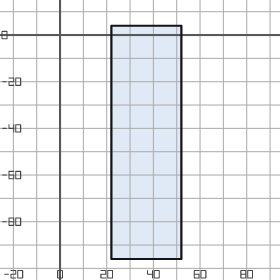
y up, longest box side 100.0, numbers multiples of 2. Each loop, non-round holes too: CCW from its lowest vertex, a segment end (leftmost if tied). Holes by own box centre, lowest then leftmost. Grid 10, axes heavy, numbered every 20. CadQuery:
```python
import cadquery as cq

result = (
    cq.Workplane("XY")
    .moveTo(22.0, -96.0)
    .lineTo(52.0, -96.0)
    .lineTo(52.0, 4.0)
    .lineTo(22.0, 4.0)
    .close()
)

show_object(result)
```